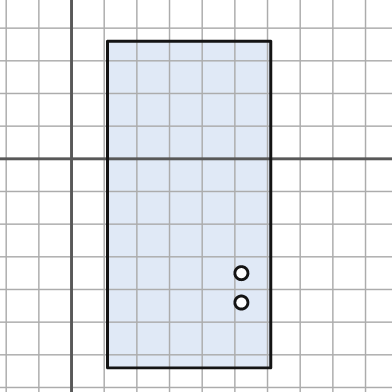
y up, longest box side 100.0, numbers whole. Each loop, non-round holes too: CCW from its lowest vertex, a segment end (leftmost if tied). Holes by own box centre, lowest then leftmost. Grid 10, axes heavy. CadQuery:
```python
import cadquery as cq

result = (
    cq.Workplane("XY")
    .moveTo(11.0, -64.0)
    .lineTo(61.0, -64.0)
    .lineTo(61.0, 36.0)
    .lineTo(11.0, 36.0)
    .close()
    .moveTo(52.0, -44.0)
    .circle(2.0)
    .moveTo(52.0, -35.0)
    .circle(2.0)
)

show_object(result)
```